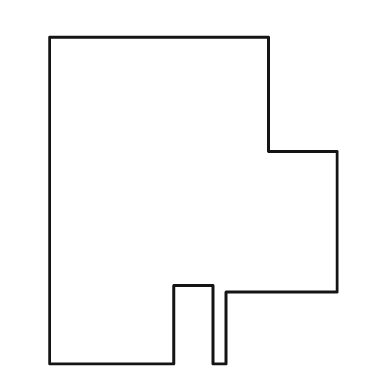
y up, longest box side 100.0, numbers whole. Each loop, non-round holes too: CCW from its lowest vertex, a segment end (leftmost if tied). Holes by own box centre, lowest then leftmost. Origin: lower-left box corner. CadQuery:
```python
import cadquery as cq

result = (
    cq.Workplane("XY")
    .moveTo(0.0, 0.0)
    .lineTo(38.0, 0.0)
    .lineTo(38.0, 24.0)
    .lineTo(50.0, 24.0)
    .lineTo(50.0, 0.0)
    .lineTo(54.0, 0.0)
    .lineTo(54.0, 22.0)
    .lineTo(88.0, 22.0)
    .lineTo(88.0, 65.0)
    .lineTo(67.0, 65.0)
    .lineTo(67.0, 100.0)
    .lineTo(0.0, 100.0)
    .close()
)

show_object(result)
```